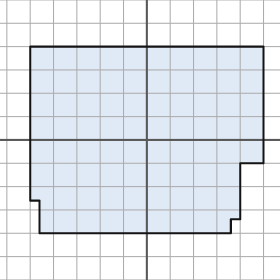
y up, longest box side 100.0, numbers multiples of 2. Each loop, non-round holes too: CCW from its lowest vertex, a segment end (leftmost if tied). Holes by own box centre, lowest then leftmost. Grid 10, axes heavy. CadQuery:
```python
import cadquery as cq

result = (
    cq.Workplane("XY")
    .moveTo(-46.0, -40.0)
    .lineTo(36.0, -40.0)
    .lineTo(36.0, -34.0)
    .lineTo(40.0, -34.0)
    .lineTo(40.0, -10.0)
    .lineTo(50.0, -10.0)
    .lineTo(50.0, 40.0)
    .lineTo(-50.0, 40.0)
    .lineTo(-50.0, -26.0)
    .lineTo(-46.0, -26.0)
    .close()
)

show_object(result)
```